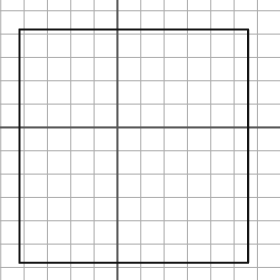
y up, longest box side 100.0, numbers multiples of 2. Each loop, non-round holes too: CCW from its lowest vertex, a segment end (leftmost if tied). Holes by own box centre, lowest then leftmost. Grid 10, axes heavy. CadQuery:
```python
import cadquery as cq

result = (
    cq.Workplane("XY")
    .moveTo(-42.0, -58.0)
    .lineTo(56.0, -58.0)
    .lineTo(56.0, 42.0)
    .lineTo(-42.0, 42.0)
    .close()
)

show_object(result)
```